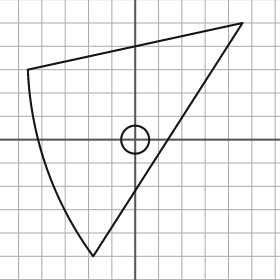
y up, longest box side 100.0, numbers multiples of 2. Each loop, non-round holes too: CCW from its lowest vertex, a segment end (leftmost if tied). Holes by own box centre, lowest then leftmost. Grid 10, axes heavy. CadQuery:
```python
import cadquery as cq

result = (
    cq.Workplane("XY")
    .moveTo(-18.0, -50.0)
    .lineTo(46.0, 50.0)
    .lineTo(-46.0, 30.0)
    .threePointArc((-38.0, -12.0), (-18.0, -50.0))
    .close()
    .moveTo(0.0, 0.0)
    .circle(6.0)
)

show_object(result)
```